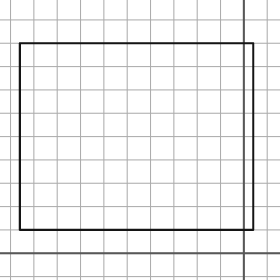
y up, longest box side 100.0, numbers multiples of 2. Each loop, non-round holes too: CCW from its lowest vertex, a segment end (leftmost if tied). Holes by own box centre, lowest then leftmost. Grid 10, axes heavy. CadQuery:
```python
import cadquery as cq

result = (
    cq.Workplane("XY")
    .moveTo(-96.0, 10.0)
    .lineTo(4.0, 10.0)
    .lineTo(4.0, 90.0)
    .lineTo(-96.0, 90.0)
    .close()
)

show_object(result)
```